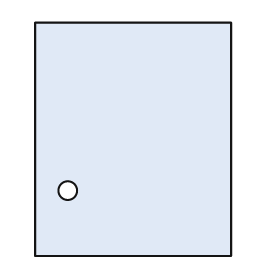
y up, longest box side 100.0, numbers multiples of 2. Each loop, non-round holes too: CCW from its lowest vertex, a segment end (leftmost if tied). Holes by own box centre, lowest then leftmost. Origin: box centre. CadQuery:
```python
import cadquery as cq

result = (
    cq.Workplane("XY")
    .moveTo(-42.0, -50.0)
    .lineTo(42.0, -50.0)
    .lineTo(42.0, 50.0)
    .lineTo(-42.0, 50.0)
    .close()
    .moveTo(-28.0, -22.0)
    .circle(4.0)
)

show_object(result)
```